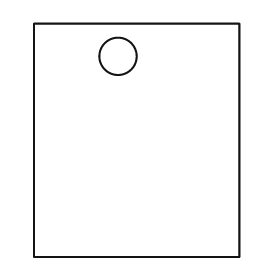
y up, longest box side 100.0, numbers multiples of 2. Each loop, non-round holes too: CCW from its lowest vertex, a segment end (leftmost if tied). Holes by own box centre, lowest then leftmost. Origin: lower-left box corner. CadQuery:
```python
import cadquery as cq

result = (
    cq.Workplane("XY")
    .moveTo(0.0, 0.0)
    .lineTo(88.0, 0.0)
    .lineTo(88.0, 100.0)
    .lineTo(0.0, 100.0)
    .close()
    .moveTo(36.0, 86.0)
    .circle(8.0)
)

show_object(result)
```